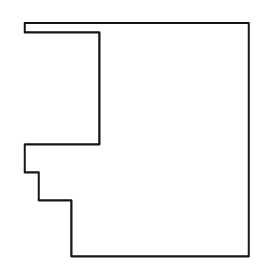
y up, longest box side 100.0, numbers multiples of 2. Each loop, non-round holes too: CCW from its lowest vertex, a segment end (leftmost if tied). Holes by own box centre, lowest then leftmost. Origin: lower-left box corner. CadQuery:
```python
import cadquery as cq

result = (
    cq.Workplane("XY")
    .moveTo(20.0, 0.0)
    .lineTo(96.0, 0.0)
    .lineTo(96.0, 100.0)
    .lineTo(0.0, 100.0)
    .lineTo(0.0, 96.0)
    .lineTo(32.0, 96.0)
    .lineTo(32.0, 48.0)
    .lineTo(0.0, 48.0)
    .lineTo(0.0, 36.0)
    .lineTo(6.0, 36.0)
    .lineTo(6.0, 24.0)
    .lineTo(20.0, 24.0)
    .close()
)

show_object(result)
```